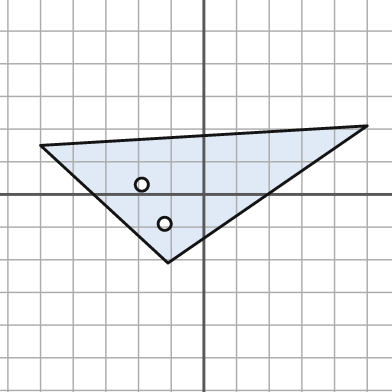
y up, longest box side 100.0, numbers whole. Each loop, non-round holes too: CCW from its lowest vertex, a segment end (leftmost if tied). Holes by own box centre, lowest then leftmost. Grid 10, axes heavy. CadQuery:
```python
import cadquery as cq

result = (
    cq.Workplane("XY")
    .moveTo(-11.0, -21.0)
    .lineTo(50.0, 21.0)
    .lineTo(-50.0, 15.0)
    .close()
    .moveTo(-12.0, -9.0)
    .circle(2.0)
    .moveTo(-19.0, 3.0)
    .circle(2.0)
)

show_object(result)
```